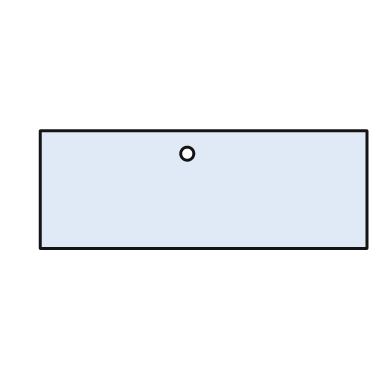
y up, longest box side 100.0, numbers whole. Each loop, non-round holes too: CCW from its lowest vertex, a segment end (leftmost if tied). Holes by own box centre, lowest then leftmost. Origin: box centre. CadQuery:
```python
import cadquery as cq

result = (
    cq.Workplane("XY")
    .moveTo(-50.0, -18.0)
    .lineTo(50.0, -18.0)
    .lineTo(50.0, 18.0)
    .lineTo(-50.0, 18.0)
    .close()
    .moveTo(-5.0, 11.0)
    .circle(2.0)
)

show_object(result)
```